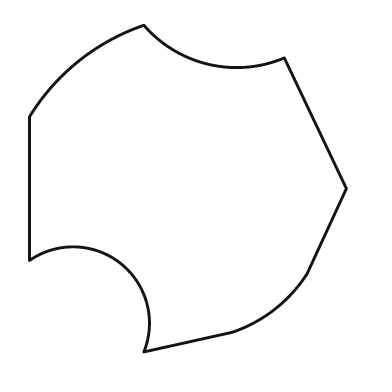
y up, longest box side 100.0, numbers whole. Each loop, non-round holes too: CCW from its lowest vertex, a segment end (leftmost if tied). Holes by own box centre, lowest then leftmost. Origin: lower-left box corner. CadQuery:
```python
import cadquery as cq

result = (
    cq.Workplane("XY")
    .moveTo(35.0, 0.0)
    .lineTo(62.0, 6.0)
    .threePointArc((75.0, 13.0), (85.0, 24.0))
    .lineTo(97.0, 50.0)
    .lineTo(78.0, 90.0)
    .threePointArc((55.0, 88.0), (35.0, 100.0))
    .threePointArc((15.0, 89.0), (0.0, 72.0))
    .lineTo(0.0, 28.0)
    .threePointArc((28.0, 27.0), (35.0, 0.0))
    .close()
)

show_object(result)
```